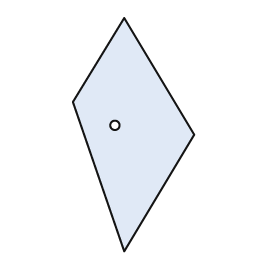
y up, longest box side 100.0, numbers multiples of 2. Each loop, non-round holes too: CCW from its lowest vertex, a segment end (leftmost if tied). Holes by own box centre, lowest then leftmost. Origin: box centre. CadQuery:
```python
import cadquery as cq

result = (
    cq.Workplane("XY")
    .moveTo(-4.0, -50.0)
    .lineTo(26.0, 0.0)
    .lineTo(-4.0, 50.0)
    .lineTo(-26.0, 14.0)
    .close()
    .moveTo(-8.0, 4.0)
    .circle(2.0)
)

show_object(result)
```